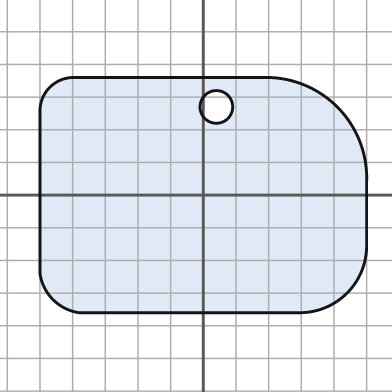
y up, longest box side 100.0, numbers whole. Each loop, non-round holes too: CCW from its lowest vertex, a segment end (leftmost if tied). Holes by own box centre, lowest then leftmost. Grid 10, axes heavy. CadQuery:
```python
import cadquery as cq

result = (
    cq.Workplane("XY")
    .moveTo(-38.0, -36.0)
    .lineTo(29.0, -36.0)
    .threePointArc((44.0, -30.0), (50.0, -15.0))
    .lineTo(50.0, 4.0)
    .threePointArc((41.0, 27.0), (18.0, 36.0))
    .lineTo(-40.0, 36.0)
    .threePointArc((-47.0, 33.0), (-50.0, 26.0))
    .lineTo(-50.0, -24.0)
    .threePointArc((-46.0, -32.0), (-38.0, -36.0))
    .close()
    .moveTo(4.0, 27.0)
    .circle(5.0)
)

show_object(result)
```